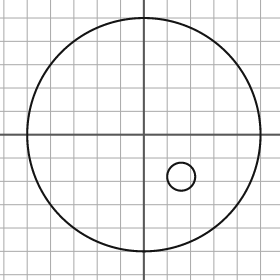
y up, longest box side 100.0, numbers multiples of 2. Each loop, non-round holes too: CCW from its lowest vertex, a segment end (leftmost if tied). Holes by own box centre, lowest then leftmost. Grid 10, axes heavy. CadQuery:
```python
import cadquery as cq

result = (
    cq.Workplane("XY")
    .moveTo(0.0, 0.0)
    .circle(50.0)
    .moveTo(16.0, -18.0)
    .circle(6.0)
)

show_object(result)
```